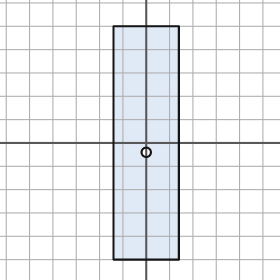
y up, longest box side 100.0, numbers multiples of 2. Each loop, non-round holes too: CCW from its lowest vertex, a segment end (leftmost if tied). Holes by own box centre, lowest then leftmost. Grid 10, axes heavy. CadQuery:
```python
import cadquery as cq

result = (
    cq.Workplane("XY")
    .moveTo(-14.0, -50.0)
    .lineTo(14.0, -50.0)
    .lineTo(14.0, 50.0)
    .lineTo(-14.0, 50.0)
    .close()
    .moveTo(0.0, -4.0)
    .circle(2.0)
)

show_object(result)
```